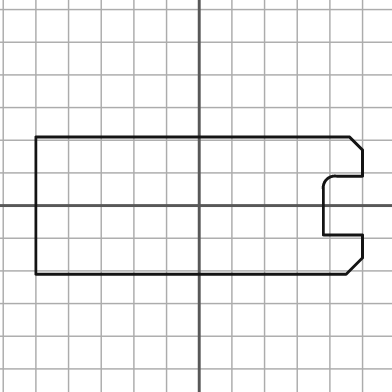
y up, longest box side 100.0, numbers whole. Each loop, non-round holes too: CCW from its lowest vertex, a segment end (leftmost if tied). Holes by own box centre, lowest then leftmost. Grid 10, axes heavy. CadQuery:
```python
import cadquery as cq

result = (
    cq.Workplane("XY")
    .moveTo(-50.0, -21.0)
    .lineTo(45.0, -21.0)
    .lineTo(50.0, -16.0)
    .lineTo(50.0, -9.0)
    .lineTo(38.0, -9.0)
    .lineTo(38.0, 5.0)
    .threePointArc((39.0, 8.0), (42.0, 9.0))
    .lineTo(50.0, 9.0)
    .lineTo(50.0, 17.0)
    .lineTo(46.0, 21.0)
    .lineTo(-50.0, 21.0)
    .close()
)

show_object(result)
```